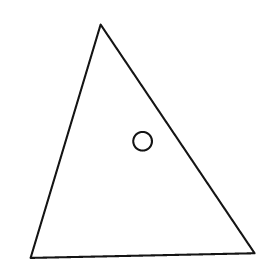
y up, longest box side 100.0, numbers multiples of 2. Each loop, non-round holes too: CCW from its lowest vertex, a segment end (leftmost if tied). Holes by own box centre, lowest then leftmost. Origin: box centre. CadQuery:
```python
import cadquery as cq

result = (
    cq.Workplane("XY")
    .moveTo(-48.0, -50.0)
    .lineTo(48.0, -48.0)
    .lineTo(-18.0, 50.0)
    .close()
    .moveTo(0.0, 0.0)
    .circle(4.0)
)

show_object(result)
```